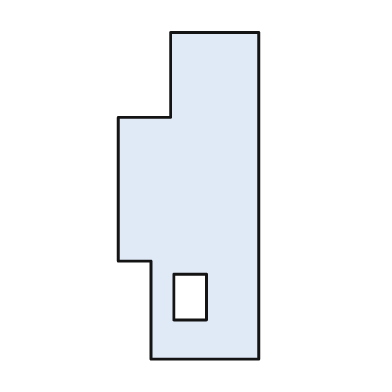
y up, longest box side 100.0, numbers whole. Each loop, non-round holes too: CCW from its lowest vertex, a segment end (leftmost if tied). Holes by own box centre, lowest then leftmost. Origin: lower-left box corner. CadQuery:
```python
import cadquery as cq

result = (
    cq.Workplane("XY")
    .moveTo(10.0, 0.0)
    .lineTo(43.0, 0.0)
    .lineTo(43.0, 100.0)
    .lineTo(16.0, 100.0)
    .lineTo(16.0, 74.0)
    .lineTo(0.0, 74.0)
    .lineTo(0.0, 30.0)
    .lineTo(10.0, 30.0)
    .close()
    .moveTo(17.0, 12.0)
    .lineTo(27.0, 12.0)
    .lineTo(27.0, 26.0)
    .lineTo(17.0, 26.0)
    .close()
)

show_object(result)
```